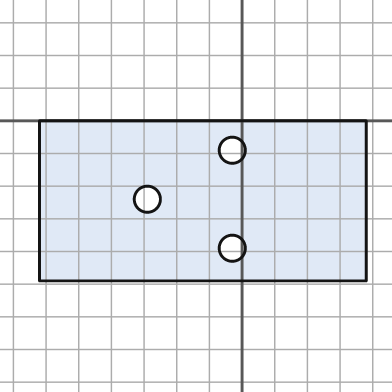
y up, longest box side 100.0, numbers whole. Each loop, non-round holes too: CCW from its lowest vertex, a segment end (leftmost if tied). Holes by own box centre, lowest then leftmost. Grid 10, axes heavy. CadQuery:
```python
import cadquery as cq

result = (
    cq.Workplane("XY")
    .moveTo(-62.0, -49.0)
    .lineTo(38.0, -49.0)
    .lineTo(38.0, 0.0)
    .lineTo(-62.0, 0.0)
    .close()
    .moveTo(-3.0, -39.0)
    .circle(4.0)
    .moveTo(-29.0, -24.0)
    .circle(4.0)
    .moveTo(-3.0, -9.0)
    .circle(4.0)
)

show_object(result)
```